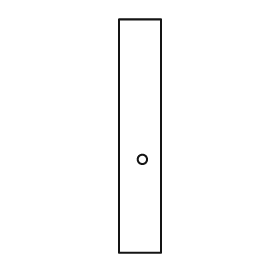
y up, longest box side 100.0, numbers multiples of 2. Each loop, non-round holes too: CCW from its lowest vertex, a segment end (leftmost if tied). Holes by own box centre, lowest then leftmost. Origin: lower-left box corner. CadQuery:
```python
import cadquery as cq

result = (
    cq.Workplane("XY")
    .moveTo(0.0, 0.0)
    .lineTo(18.0, 0.0)
    .lineTo(18.0, 100.0)
    .lineTo(0.0, 100.0)
    .close()
    .moveTo(10.0, 40.0)
    .circle(2.0)
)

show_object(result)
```